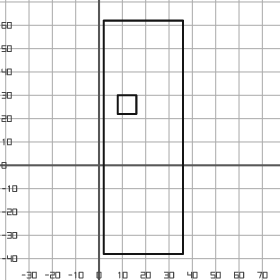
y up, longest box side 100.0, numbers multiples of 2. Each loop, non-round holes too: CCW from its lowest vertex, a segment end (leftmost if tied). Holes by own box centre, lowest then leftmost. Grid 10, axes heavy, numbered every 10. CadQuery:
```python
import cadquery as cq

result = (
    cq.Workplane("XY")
    .moveTo(2.0, -38.0)
    .lineTo(36.0, -38.0)
    .lineTo(36.0, 62.0)
    .lineTo(2.0, 62.0)
    .close()
    .moveTo(8.0, 22.0)
    .lineTo(16.0, 22.0)
    .lineTo(16.0, 30.0)
    .lineTo(8.0, 30.0)
    .close()
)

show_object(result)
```